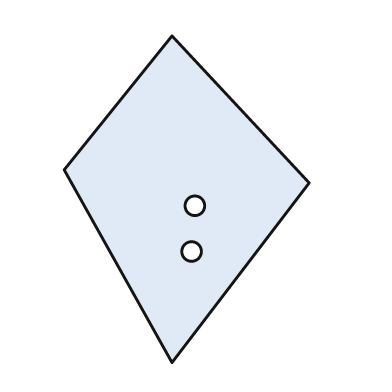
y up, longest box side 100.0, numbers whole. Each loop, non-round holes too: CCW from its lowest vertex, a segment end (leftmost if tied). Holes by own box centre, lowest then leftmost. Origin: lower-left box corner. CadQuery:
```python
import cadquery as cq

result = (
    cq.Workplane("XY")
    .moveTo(33.0, 0.0)
    .lineTo(75.0, 55.0)
    .lineTo(33.0, 100.0)
    .lineTo(0.0, 59.0)
    .close()
    .moveTo(39.0, 34.0)
    .circle(3.0)
    .moveTo(40.0, 48.0)
    .circle(3.0)
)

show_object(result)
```